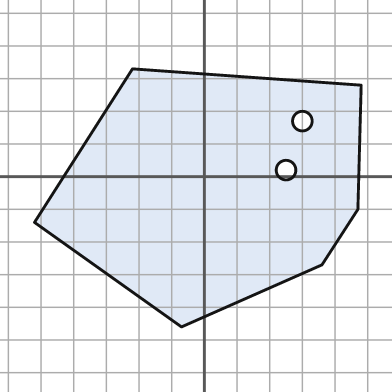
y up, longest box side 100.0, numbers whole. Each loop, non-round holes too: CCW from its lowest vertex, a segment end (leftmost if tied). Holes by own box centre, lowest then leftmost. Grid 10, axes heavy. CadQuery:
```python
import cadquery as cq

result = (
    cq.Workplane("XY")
    .moveTo(-7.0, -46.0)
    .lineTo(36.0, -27.0)
    .lineTo(47.0, -10.0)
    .lineTo(48.0, 28.0)
    .lineTo(-22.0, 33.0)
    .lineTo(-52.0, -14.0)
    .close()
    .moveTo(25.0, 2.0)
    .circle(3.0)
    .moveTo(30.0, 17.0)
    .circle(3.0)
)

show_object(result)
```